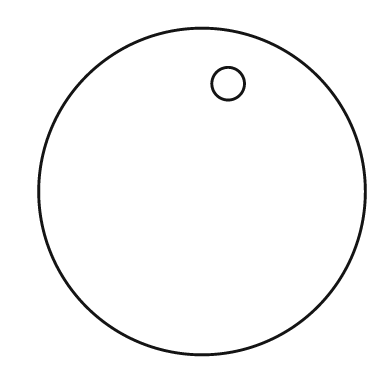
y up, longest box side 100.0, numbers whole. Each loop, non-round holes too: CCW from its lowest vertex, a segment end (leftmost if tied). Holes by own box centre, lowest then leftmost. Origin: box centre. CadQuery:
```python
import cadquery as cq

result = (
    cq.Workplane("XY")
    .moveTo(0.0, 0.0)
    .circle(50.0)
    .moveTo(8.0, 33.0)
    .circle(5.0)
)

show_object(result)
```